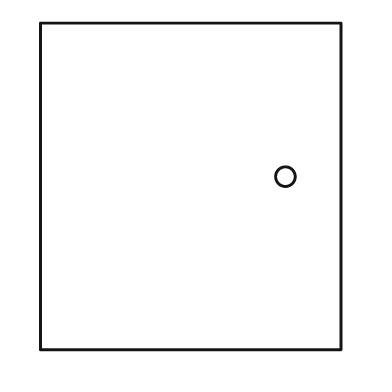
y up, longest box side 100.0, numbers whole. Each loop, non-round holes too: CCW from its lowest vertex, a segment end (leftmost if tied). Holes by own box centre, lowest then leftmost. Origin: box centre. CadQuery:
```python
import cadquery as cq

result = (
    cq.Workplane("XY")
    .moveTo(-46.0, -50.0)
    .lineTo(46.0, -50.0)
    .lineTo(46.0, 50.0)
    .lineTo(-46.0, 50.0)
    .close()
    .moveTo(29.0, 3.0)
    .circle(3.0)
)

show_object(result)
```